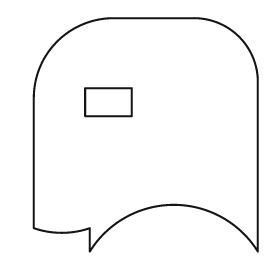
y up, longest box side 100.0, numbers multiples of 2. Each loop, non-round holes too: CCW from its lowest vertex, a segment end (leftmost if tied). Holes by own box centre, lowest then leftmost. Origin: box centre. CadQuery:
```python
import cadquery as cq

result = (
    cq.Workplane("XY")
    .moveTo(-24.0, -50.0)
    .threePointArc((12.0, -30.0), (48.0, -50.0))
    .lineTo(48.0, 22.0)
    .threePointArc((40.0, 42.0), (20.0, 50.0))
    .lineTo(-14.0, 50.0)
    .threePointArc((-38.0, 40.0), (-48.0, 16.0))
    .lineTo(-48.0, -40.0)
    .threePointArc((-36.0, -42.0), (-24.0, -40.0))
    .close()
    .moveTo(-26.0, 8.0)
    .lineTo(-6.0, 8.0)
    .lineTo(-6.0, 20.0)
    .lineTo(-26.0, 20.0)
    .close()
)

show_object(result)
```